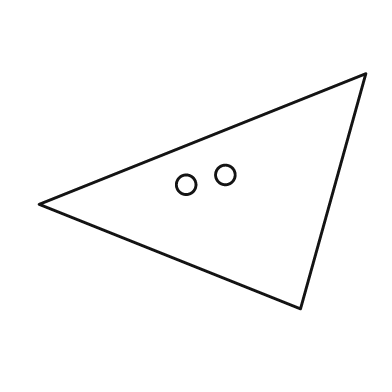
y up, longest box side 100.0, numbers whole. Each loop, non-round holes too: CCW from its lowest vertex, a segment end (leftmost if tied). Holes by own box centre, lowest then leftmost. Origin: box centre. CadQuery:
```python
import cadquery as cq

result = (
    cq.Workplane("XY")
    .moveTo(30.0, -36.0)
    .lineTo(50.0, 36.0)
    .lineTo(-50.0, -4.0)
    .close()
    .moveTo(-5.0, 2.0)
    .circle(3.0)
    .moveTo(7.0, 5.0)
    .circle(3.0)
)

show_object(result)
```